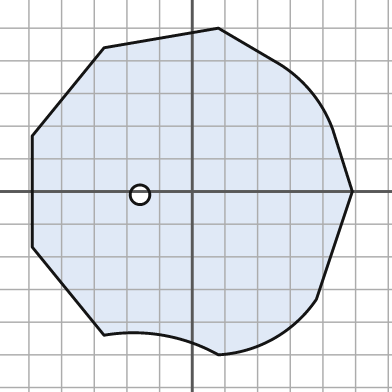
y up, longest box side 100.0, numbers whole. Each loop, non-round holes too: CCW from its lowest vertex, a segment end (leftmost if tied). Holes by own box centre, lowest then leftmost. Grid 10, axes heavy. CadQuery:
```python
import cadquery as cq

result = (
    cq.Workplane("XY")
    .moveTo(8.0, -50.0)
    .threePointArc((25.0, -45.0), (38.0, -33.0))
    .lineTo(49.0, 0.0)
    .lineTo(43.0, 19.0)
    .threePointArc((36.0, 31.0), (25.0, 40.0))
    .lineTo(8.0, 50.0)
    .lineTo(-27.0, 44.0)
    .lineTo(-49.0, 17.0)
    .lineTo(-49.0, -17.0)
    .lineTo(-27.0, -44.0)
    .threePointArc((-9.0, -44.0), (8.0, -50.0))
    .close()
    .moveTo(-16.0, -1.0)
    .circle(3.0)
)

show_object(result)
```